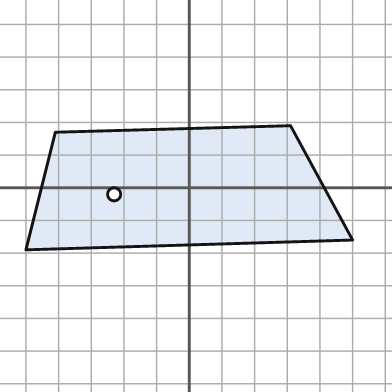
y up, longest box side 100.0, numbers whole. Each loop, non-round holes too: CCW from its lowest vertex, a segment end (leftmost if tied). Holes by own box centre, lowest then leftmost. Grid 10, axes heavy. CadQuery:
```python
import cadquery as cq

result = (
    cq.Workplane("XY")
    .moveTo(-50.0, -19.0)
    .lineTo(50.0, -16.0)
    .lineTo(31.0, 19.0)
    .lineTo(-41.0, 17.0)
    .close()
    .moveTo(-23.0, -2.0)
    .circle(2.0)
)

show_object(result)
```